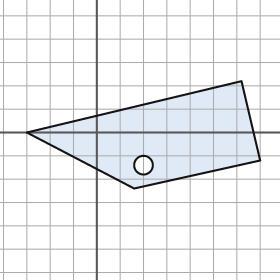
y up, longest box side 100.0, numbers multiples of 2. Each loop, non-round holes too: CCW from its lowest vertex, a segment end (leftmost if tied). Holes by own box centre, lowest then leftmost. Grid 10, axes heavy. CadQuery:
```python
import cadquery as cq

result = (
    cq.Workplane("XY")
    .moveTo(16.0, -24.0)
    .lineTo(70.0, -12.0)
    .lineTo(62.0, 22.0)
    .lineTo(-30.0, 0.0)
    .close()
    .moveTo(20.0, -14.0)
    .circle(4.0)
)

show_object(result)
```